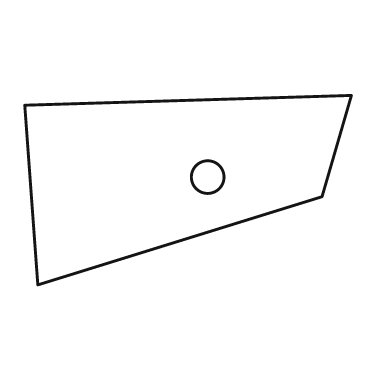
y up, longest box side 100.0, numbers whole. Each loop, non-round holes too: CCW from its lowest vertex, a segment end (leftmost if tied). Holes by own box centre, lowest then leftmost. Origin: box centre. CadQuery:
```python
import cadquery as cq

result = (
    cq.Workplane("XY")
    .moveTo(-46.0, -29.0)
    .lineTo(41.0, -2.0)
    .lineTo(50.0, 29.0)
    .lineTo(-50.0, 26.0)
    .close()
    .moveTo(6.0, 4.0)
    .circle(5.0)
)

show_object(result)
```